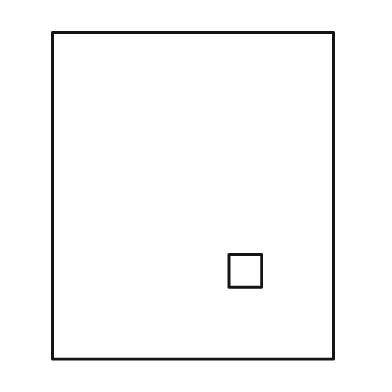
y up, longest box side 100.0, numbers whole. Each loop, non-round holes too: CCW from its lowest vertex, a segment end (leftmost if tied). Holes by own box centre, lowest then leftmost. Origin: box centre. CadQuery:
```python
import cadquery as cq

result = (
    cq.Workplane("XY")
    .moveTo(-43.0, -50.0)
    .lineTo(43.0, -50.0)
    .lineTo(43.0, 50.0)
    .lineTo(-43.0, 50.0)
    .close()
    .moveTo(11.0, -28.0)
    .lineTo(21.0, -28.0)
    .lineTo(21.0, -18.0)
    .lineTo(11.0, -18.0)
    .close()
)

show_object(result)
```